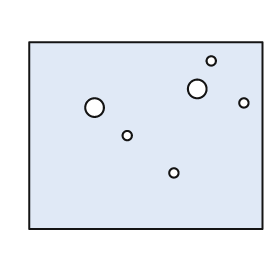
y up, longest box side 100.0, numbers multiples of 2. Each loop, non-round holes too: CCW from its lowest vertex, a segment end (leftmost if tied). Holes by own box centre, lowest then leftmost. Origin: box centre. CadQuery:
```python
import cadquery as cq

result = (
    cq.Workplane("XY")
    .moveTo(-50.0, -40.0)
    .lineTo(50.0, -40.0)
    .lineTo(50.0, 40.0)
    .lineTo(-50.0, 40.0)
    .close()
    .moveTo(12.0, -16.0)
    .circle(2.0)
    .moveTo(-8.0, 0.0)
    .circle(2.0)
    .moveTo(-22.0, 12.0)
    .circle(4.0)
    .moveTo(42.0, 14.0)
    .circle(2.0)
    .moveTo(22.0, 20.0)
    .circle(4.0)
    .moveTo(28.0, 32.0)
    .circle(2.0)
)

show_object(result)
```